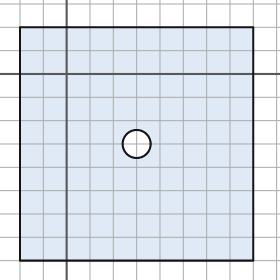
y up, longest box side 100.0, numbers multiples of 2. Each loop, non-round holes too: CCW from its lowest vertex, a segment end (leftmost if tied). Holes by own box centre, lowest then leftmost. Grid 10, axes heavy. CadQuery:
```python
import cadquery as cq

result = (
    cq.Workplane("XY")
    .moveTo(-20.0, -80.0)
    .lineTo(80.0, -80.0)
    .lineTo(80.0, 20.0)
    .lineTo(-20.0, 20.0)
    .close()
    .moveTo(30.0, -30.0)
    .circle(6.0)
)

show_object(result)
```